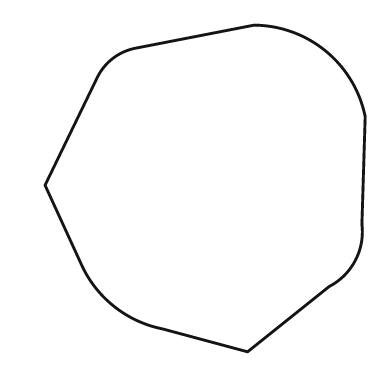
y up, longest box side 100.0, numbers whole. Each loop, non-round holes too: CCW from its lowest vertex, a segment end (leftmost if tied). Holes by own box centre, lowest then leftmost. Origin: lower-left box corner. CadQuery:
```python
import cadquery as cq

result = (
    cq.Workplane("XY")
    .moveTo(62.0, 0.0)
    .lineTo(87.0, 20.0)
    .threePointArc((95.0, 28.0), (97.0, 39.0))
    .lineTo(98.0, 72.0)
    .threePointArc((86.0, 92.0), (64.0, 100.0))
    .lineTo(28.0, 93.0)
    .threePointArc((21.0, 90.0), (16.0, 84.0))
    .lineTo(0.0, 51.0)
    .lineTo(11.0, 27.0)
    .threePointArc((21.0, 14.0), (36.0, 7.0))
    .close()
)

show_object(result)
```